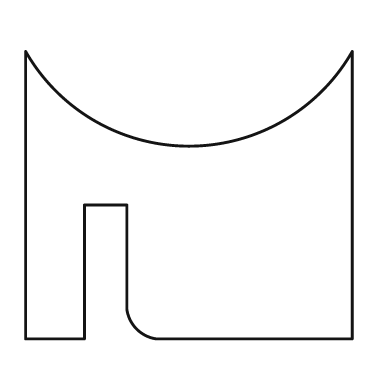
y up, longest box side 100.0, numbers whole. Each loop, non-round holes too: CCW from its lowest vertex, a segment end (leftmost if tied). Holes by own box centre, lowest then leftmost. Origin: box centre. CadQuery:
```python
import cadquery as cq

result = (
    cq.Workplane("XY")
    .moveTo(-50.0, -44.0)
    .lineTo(-32.0, -44.0)
    .lineTo(-32.0, -3.0)
    .lineTo(-19.0, -3.0)
    .lineTo(-19.0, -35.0)
    .threePointArc((-16.0, -41.0), (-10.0, -44.0))
    .lineTo(50.0, -44.0)
    .lineTo(50.0, 44.0)
    .threePointArc((0.0, 15.0), (-50.0, 44.0))
    .close()
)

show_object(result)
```